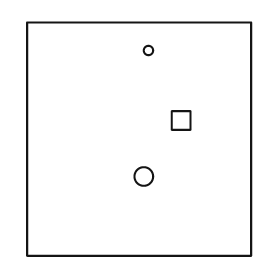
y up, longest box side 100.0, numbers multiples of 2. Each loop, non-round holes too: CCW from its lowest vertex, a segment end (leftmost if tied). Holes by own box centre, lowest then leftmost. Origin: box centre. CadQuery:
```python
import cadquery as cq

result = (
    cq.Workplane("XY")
    .moveTo(-48.0, -50.0)
    .lineTo(48.0, -50.0)
    .lineTo(48.0, 50.0)
    .lineTo(-48.0, 50.0)
    .close()
    .moveTo(2.0, -16.0)
    .circle(4.0)
    .moveTo(14.0, 4.0)
    .lineTo(22.0, 4.0)
    .lineTo(22.0, 12.0)
    .lineTo(14.0, 12.0)
    .close()
    .moveTo(4.0, 38.0)
    .circle(2.0)
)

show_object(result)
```